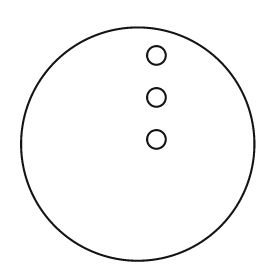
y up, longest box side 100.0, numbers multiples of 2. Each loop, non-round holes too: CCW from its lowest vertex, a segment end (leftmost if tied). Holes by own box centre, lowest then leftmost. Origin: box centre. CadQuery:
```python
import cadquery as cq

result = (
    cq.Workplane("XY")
    .moveTo(0.0, 0.0)
    .circle(50.0)
    .moveTo(8.0, 2.0)
    .circle(4.0)
    .moveTo(8.0, 20.0)
    .circle(4.0)
    .moveTo(8.0, 38.0)
    .circle(4.0)
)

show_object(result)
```